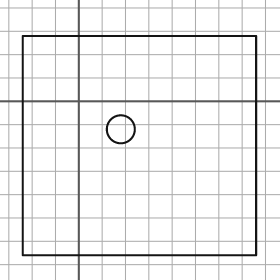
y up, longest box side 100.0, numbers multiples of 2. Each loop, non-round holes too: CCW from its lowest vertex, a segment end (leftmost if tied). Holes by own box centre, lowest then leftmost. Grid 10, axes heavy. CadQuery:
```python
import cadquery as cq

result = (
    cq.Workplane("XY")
    .moveTo(-24.0, -66.0)
    .lineTo(76.0, -66.0)
    .lineTo(76.0, 28.0)
    .lineTo(-24.0, 28.0)
    .close()
    .moveTo(18.0, -12.0)
    .circle(6.0)
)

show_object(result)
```